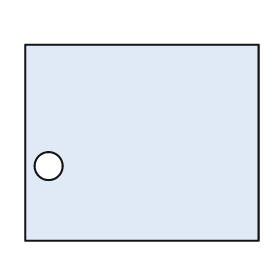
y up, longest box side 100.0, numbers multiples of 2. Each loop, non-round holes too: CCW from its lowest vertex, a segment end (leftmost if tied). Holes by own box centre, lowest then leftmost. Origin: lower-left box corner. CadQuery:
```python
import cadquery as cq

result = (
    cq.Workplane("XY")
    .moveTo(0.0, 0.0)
    .lineTo(100.0, 0.0)
    .lineTo(100.0, 84.0)
    .lineTo(0.0, 84.0)
    .close()
    .moveTo(10.0, 32.0)
    .circle(6.0)
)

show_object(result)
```